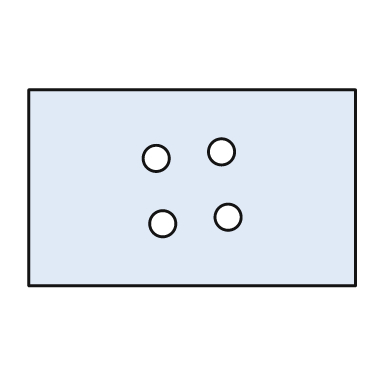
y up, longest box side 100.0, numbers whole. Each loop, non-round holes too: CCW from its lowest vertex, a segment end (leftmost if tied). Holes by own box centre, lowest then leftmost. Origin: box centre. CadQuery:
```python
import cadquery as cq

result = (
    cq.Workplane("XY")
    .moveTo(-50.0, -30.0)
    .lineTo(50.0, -30.0)
    .lineTo(50.0, 30.0)
    .lineTo(-50.0, 30.0)
    .close()
    .moveTo(-9.0, -11.0)
    .circle(4.0)
    .moveTo(11.0, -9.0)
    .circle(4.0)
    .moveTo(-11.0, 9.0)
    .circle(4.0)
    .moveTo(9.0, 11.0)
    .circle(4.0)
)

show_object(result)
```